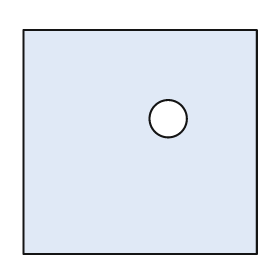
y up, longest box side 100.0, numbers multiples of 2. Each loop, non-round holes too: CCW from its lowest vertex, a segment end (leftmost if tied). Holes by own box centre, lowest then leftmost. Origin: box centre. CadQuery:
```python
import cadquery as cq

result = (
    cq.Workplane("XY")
    .moveTo(-50.0, -48.0)
    .lineTo(50.0, -48.0)
    .lineTo(50.0, 48.0)
    .lineTo(-50.0, 48.0)
    .close()
    .moveTo(12.0, 10.0)
    .circle(8.0)
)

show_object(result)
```